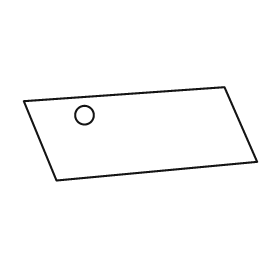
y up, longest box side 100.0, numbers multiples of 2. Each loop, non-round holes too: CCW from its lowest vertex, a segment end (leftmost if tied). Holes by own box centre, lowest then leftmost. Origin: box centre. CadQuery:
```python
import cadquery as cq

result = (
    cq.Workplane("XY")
    .moveTo(-36.0, -20.0)
    .lineTo(50.0, -12.0)
    .lineTo(36.0, 20.0)
    .lineTo(-50.0, 14.0)
    .close()
    .moveTo(-24.0, 8.0)
    .circle(4.0)
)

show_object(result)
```